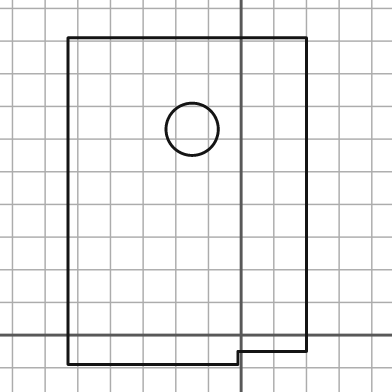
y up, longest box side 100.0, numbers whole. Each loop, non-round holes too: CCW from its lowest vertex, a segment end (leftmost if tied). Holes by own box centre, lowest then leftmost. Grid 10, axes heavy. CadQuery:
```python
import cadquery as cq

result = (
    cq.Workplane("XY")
    .moveTo(-53.0, -9.0)
    .lineTo(-1.0, -9.0)
    .lineTo(-1.0, -5.0)
    .lineTo(20.0, -5.0)
    .lineTo(20.0, 91.0)
    .lineTo(-53.0, 91.0)
    .close()
    .moveTo(-15.0, 63.0)
    .circle(8.0)
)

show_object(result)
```